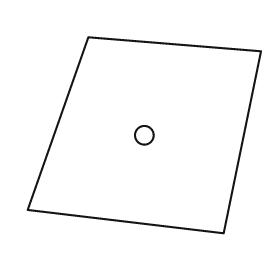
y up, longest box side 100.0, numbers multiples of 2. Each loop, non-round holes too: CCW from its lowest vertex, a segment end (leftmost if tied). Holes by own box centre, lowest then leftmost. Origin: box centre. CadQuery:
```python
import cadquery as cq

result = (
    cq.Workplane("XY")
    .moveTo(34.0, -42.0)
    .lineTo(50.0, 36.0)
    .lineTo(-24.0, 42.0)
    .lineTo(-50.0, -32.0)
    .close()
    .moveTo(0.0, 0.0)
    .circle(4.0)
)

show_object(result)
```